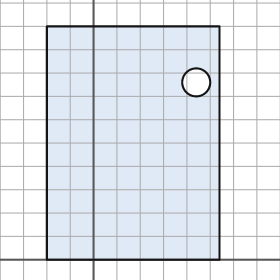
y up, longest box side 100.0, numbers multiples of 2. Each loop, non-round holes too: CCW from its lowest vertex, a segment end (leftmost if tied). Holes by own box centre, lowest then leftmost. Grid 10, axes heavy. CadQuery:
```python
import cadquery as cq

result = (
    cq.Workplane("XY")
    .moveTo(-20.0, 0.0)
    .lineTo(54.0, 0.0)
    .lineTo(54.0, 100.0)
    .lineTo(-20.0, 100.0)
    .close()
    .moveTo(44.0, 76.0)
    .circle(6.0)
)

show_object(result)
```